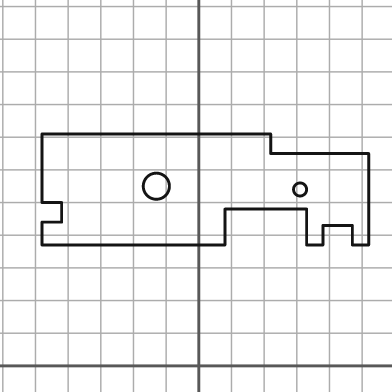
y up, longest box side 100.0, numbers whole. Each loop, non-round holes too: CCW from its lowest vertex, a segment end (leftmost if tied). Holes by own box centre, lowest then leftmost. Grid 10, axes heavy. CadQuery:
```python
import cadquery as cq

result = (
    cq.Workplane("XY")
    .moveTo(-48.0, 37.0)
    .lineTo(8.0, 37.0)
    .lineTo(8.0, 48.0)
    .lineTo(33.0, 48.0)
    .lineTo(33.0, 37.0)
    .lineTo(38.0, 37.0)
    .lineTo(38.0, 43.0)
    .lineTo(47.0, 43.0)
    .lineTo(47.0, 37.0)
    .lineTo(52.0, 37.0)
    .lineTo(52.0, 65.0)
    .lineTo(22.0, 65.0)
    .lineTo(22.0, 71.0)
    .lineTo(-48.0, 71.0)
    .lineTo(-48.0, 50.0)
    .lineTo(-42.0, 50.0)
    .lineTo(-42.0, 44.0)
    .lineTo(-48.0, 44.0)
    .close()
    .moveTo(31.0, 54.0)
    .circle(2.0)
    .moveTo(-13.0, 55.0)
    .circle(4.0)
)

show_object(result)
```